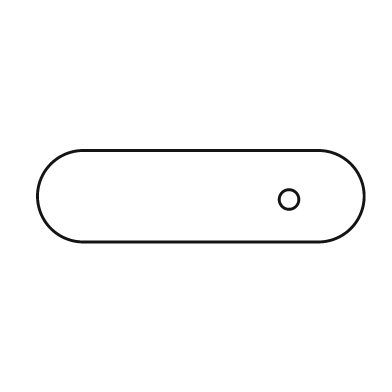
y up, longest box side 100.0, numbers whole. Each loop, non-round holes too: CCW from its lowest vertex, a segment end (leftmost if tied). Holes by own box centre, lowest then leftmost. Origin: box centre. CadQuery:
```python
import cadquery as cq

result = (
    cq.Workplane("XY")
    .moveTo(-36.0, -14.0)
    .lineTo(36.0, -14.0)
    .threePointArc((50.0, 0.0), (36.0, 14.0))
    .lineTo(-36.0, 14.0)
    .threePointArc((-50.0, 0.0), (-36.0, -14.0))
    .close()
    .moveTo(27.0, -1.0)
    .circle(3.0)
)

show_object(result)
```